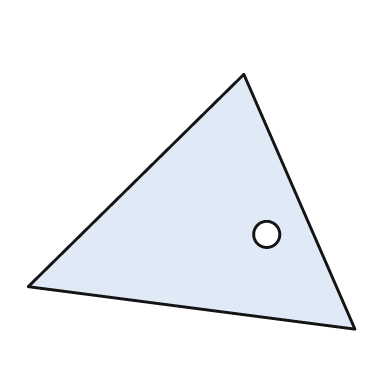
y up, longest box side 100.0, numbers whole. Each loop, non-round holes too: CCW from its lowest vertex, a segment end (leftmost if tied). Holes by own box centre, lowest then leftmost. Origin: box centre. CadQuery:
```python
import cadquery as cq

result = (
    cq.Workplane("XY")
    .moveTo(50.0, -39.0)
    .lineTo(16.0, 39.0)
    .lineTo(-50.0, -26.0)
    .close()
    .moveTo(23.0, -10.0)
    .circle(4.0)
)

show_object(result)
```